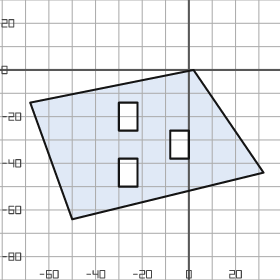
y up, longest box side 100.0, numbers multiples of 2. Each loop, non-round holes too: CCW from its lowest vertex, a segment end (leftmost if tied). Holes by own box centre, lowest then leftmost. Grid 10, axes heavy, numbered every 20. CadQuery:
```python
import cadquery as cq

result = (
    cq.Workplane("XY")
    .moveTo(-50.0, -64.0)
    .lineTo(32.0, -44.0)
    .lineTo(2.0, 0.0)
    .lineTo(-68.0, -14.0)
    .close()
    .moveTo(-30.0, -50.0)
    .lineTo(-22.0, -50.0)
    .lineTo(-22.0, -38.0)
    .lineTo(-30.0, -38.0)
    .close()
    .moveTo(-8.0, -38.0)
    .lineTo(0.0, -38.0)
    .lineTo(0.0, -26.0)
    .lineTo(-8.0, -26.0)
    .close()
    .moveTo(-30.0, -26.0)
    .lineTo(-22.0, -26.0)
    .lineTo(-22.0, -14.0)
    .lineTo(-30.0, -14.0)
    .close()
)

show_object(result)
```